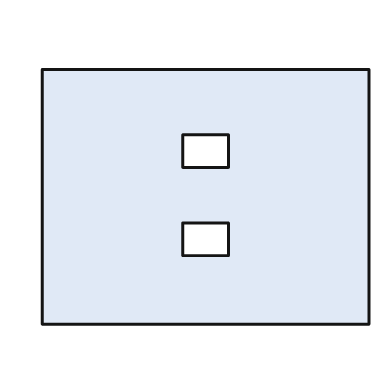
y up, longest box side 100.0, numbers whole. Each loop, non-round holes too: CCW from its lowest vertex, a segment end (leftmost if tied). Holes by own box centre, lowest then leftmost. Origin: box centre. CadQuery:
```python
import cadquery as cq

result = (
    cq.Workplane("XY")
    .moveTo(-50.0, -39.0)
    .lineTo(50.0, -39.0)
    .lineTo(50.0, 39.0)
    .lineTo(-50.0, 39.0)
    .close()
    .moveTo(-7.0, -18.0)
    .lineTo(7.0, -18.0)
    .lineTo(7.0, -8.0)
    .lineTo(-7.0, -8.0)
    .close()
    .moveTo(-7.0, 9.0)
    .lineTo(7.0, 9.0)
    .lineTo(7.0, 19.0)
    .lineTo(-7.0, 19.0)
    .close()
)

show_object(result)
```